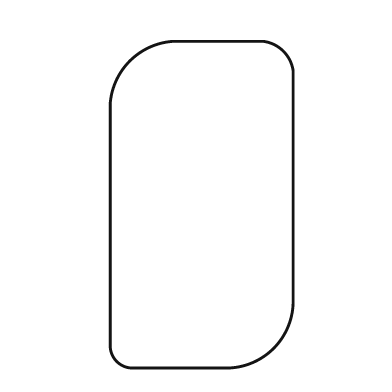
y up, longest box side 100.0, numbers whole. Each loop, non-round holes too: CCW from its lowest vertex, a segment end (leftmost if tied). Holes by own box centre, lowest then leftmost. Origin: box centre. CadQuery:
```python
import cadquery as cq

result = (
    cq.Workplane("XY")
    .moveTo(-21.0, -50.0)
    .lineTo(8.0, -50.0)
    .threePointArc((22.0, -44.0), (28.0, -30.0))
    .lineTo(28.0, 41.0)
    .threePointArc((25.0, 47.0), (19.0, 50.0))
    .lineTo(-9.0, 50.0)
    .threePointArc((-22.0, 44.0), (-28.0, 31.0))
    .lineTo(-28.0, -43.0)
    .threePointArc((-26.0, -48.0), (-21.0, -50.0))
    .close()
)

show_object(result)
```